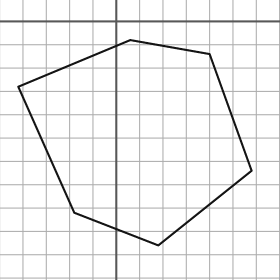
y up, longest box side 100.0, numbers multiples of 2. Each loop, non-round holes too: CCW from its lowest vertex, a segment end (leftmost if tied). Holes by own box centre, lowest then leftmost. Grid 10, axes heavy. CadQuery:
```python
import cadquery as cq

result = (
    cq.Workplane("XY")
    .moveTo(18.0, -96.0)
    .lineTo(58.0, -64.0)
    .lineTo(40.0, -14.0)
    .lineTo(6.0, -8.0)
    .lineTo(-42.0, -28.0)
    .lineTo(-18.0, -82.0)
    .close()
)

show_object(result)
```